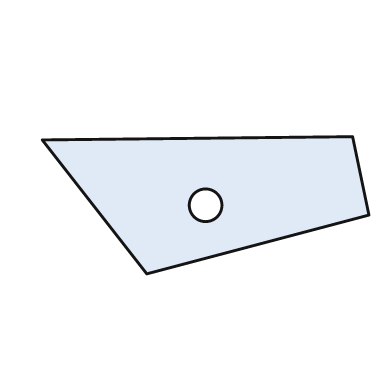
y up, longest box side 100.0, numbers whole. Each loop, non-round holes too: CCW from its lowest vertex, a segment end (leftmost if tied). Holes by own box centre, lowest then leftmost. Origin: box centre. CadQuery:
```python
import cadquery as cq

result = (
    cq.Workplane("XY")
    .moveTo(-18.0, -21.0)
    .lineTo(50.0, -3.0)
    .lineTo(45.0, 21.0)
    .lineTo(-50.0, 20.0)
    .close()
    .moveTo(0.0, 0.0)
    .circle(5.0)
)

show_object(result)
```